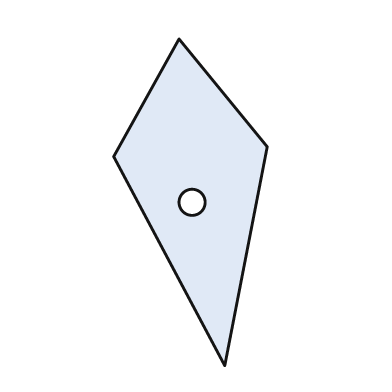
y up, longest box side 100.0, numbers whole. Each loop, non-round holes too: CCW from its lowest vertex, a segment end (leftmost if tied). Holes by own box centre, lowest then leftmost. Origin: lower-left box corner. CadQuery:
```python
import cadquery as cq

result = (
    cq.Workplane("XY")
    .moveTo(34.0, 0.0)
    .lineTo(47.0, 67.0)
    .lineTo(20.0, 100.0)
    .lineTo(0.0, 64.0)
    .close()
    .moveTo(24.0, 50.0)
    .circle(4.0)
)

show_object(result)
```